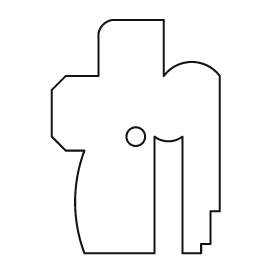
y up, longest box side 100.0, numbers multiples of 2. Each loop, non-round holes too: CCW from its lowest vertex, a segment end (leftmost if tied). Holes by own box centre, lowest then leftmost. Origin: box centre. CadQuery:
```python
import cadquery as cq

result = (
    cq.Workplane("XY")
    .moveTo(-22.0, -50.0)
    .lineTo(8.0, -50.0)
    .lineTo(8.0, 0.0)
    .threePointArc((14.0, -2.0), (20.0, 0.0))
    .lineTo(20.0, -50.0)
    .lineTo(28.0, -50.0)
    .lineTo(28.0, -46.0)
    .lineTo(32.0, -46.0)
    .lineTo(32.0, -32.0)
    .lineTo(36.0, -32.0)
    .lineTo(36.0, 26.0)
    .threePointArc((24.0, 32.0), (12.0, 26.0))
    .lineTo(12.0, 50.0)
    .lineTo(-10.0, 50.0)
    .threePointArc((-14.0, 48.0), (-16.0, 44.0))
    .lineTo(-16.0, 26.0)
    .lineTo(-30.0, 26.0)
    .lineTo(-36.0, 20.0)
    .lineTo(-36.0, 0.0)
    .lineTo(-30.0, -6.0)
    .lineTo(-22.0, -6.0)
    .threePointArc((-26.0, -28.0), (-22.0, -50.0))
    .close()
    .moveTo(0.0, 0.0)
    .circle(4.0)
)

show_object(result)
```